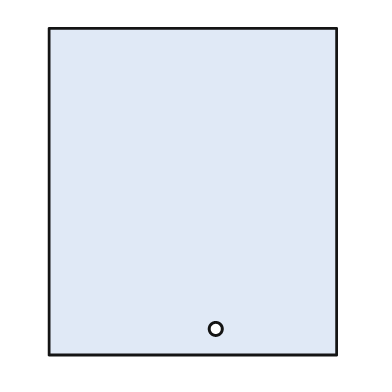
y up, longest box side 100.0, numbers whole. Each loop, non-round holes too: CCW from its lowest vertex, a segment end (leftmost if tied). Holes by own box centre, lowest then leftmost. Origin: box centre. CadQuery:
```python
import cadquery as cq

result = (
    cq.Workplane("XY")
    .moveTo(-44.0, -50.0)
    .lineTo(44.0, -50.0)
    .lineTo(44.0, 50.0)
    .lineTo(-44.0, 50.0)
    .close()
    .moveTo(7.0, -42.0)
    .circle(2.0)
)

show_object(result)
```